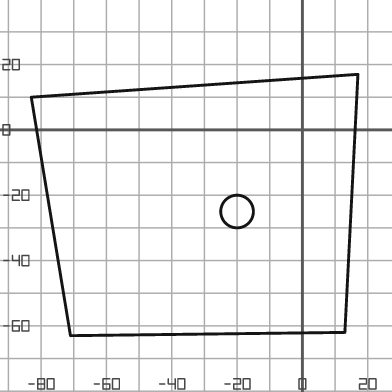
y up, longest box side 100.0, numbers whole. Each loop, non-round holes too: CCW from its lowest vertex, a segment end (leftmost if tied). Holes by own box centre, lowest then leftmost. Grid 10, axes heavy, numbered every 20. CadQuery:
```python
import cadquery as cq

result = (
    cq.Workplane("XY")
    .moveTo(-71.0, -63.0)
    .lineTo(13.0, -62.0)
    .lineTo(17.0, 17.0)
    .lineTo(-83.0, 10.0)
    .close()
    .moveTo(-20.0, -25.0)
    .circle(5.0)
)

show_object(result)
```